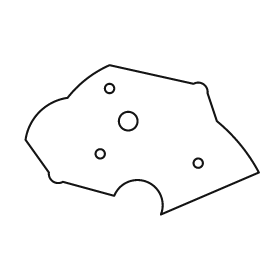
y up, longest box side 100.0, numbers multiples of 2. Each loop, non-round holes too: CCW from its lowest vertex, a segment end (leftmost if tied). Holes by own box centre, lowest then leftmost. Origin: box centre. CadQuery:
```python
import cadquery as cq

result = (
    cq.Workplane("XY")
    .moveTo(8.0, -32.0)
    .lineTo(50.0, -14.0)
    .threePointArc((42.0, -2.0), (32.0, 8.0))
    .lineTo(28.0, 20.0)
    .threePointArc((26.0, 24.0), (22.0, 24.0))
    .lineTo(-14.0, 32.0)
    .threePointArc((-24.0, 26.0), (-32.0, 18.0))
    .threePointArc((-44.0, 12.0), (-50.0, 0.0))
    .lineTo(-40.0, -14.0)
    .threePointArc((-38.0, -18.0), (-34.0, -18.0))
    .lineTo(-12.0, -24.0)
    .threePointArc((2.0, -18.0), (8.0, -32.0))
    .close()
    .moveTo(24.0, -10.0)
    .circle(2.0)
    .moveTo(-18.0, -6.0)
    .circle(2.0)
    .moveTo(-6.0, 8.0)
    .circle(4.0)
    .moveTo(-14.0, 22.0)
    .circle(2.0)
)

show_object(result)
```